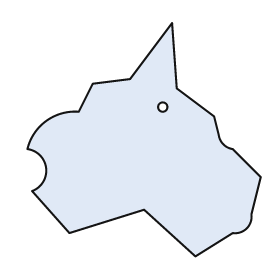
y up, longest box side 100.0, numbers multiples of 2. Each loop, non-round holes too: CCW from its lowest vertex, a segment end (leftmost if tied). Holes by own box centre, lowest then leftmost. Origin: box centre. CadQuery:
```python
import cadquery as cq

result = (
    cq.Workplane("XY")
    .moveTo(22.0, -50.0)
    .lineTo(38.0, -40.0)
    .threePointArc((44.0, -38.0), (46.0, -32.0))
    .lineTo(50.0, -16.0)
    .lineTo(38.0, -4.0)
    .threePointArc((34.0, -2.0), (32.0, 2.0))
    .lineTo(30.0, 10.0)
    .lineTo(14.0, 22.0)
    .lineTo(12.0, 50.0)
    .lineTo(-6.0, 26.0)
    .lineTo(-22.0, 24.0)
    .lineTo(-28.0, 12.0)
    .threePointArc((-42.0, 8.0), (-50.0, -4.0))
    .threePointArc((-42.0, -12.0), (-48.0, -22.0))
    .lineTo(-32.0, -40.0)
    .lineTo(0.0, -30.0)
    .close()
    .moveTo(8.0, 14.0)
    .circle(2.0)
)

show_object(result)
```